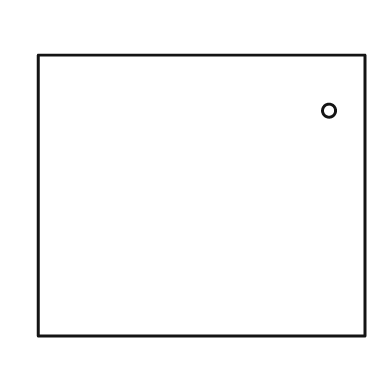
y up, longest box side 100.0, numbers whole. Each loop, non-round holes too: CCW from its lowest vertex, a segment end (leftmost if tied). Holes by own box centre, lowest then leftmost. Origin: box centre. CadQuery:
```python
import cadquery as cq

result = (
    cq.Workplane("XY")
    .moveTo(-50.0, -43.0)
    .lineTo(50.0, -43.0)
    .lineTo(50.0, 43.0)
    .lineTo(-50.0, 43.0)
    .close()
    .moveTo(39.0, 26.0)
    .circle(2.0)
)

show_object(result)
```